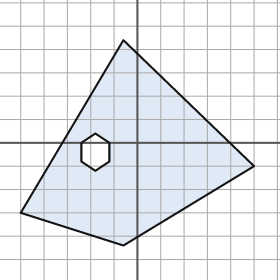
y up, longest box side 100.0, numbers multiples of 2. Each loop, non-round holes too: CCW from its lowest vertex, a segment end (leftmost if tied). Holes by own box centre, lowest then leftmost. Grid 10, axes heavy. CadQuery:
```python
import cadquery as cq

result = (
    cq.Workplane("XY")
    .moveTo(-6.0, -44.0)
    .lineTo(50.0, -10.0)
    .lineTo(-6.0, 44.0)
    .lineTo(-50.0, -30.0)
    .close()
    .moveTo(-18.0, -12.0)
    .lineTo(-12.0, -8.0)
    .lineTo(-12.0, 0.0)
    .lineTo(-18.0, 4.0)
    .lineTo(-24.0, 0.0)
    .lineTo(-24.0, -8.0)
    .close()
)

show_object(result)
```